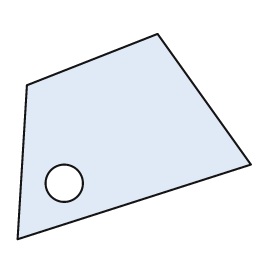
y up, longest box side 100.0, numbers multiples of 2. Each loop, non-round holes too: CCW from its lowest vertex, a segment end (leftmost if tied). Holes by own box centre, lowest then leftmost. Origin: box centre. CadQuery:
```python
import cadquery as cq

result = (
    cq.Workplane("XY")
    .moveTo(-50.0, -44.0)
    .lineTo(50.0, -12.0)
    .lineTo(10.0, 44.0)
    .lineTo(-46.0, 22.0)
    .close()
    .moveTo(-30.0, -20.0)
    .circle(8.0)
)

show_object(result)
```